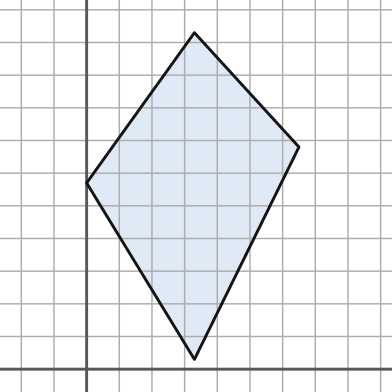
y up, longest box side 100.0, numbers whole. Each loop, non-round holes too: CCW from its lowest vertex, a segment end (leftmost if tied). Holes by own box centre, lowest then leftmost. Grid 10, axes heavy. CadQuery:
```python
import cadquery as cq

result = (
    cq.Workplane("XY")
    .moveTo(33.0, 3.0)
    .lineTo(65.0, 68.0)
    .lineTo(33.0, 103.0)
    .lineTo(0.0, 57.0)
    .close()
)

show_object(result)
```